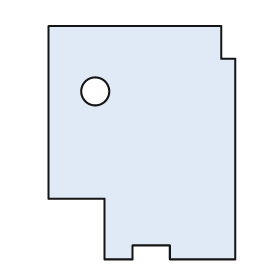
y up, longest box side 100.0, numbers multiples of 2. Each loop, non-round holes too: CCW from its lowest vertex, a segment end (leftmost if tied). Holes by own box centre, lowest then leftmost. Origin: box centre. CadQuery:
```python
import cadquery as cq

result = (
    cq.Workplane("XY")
    .moveTo(-16.0, -50.0)
    .lineTo(-4.0, -50.0)
    .lineTo(-4.0, -44.0)
    .lineTo(12.0, -44.0)
    .lineTo(12.0, -50.0)
    .lineTo(40.0, -50.0)
    .lineTo(40.0, 36.0)
    .lineTo(34.0, 36.0)
    .lineTo(34.0, 50.0)
    .lineTo(-40.0, 50.0)
    .lineTo(-40.0, -24.0)
    .lineTo(-16.0, -24.0)
    .close()
    .moveTo(-20.0, 22.0)
    .circle(6.0)
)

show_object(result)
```